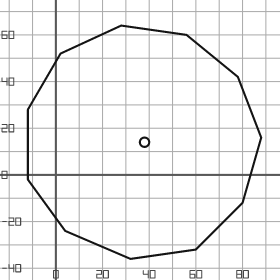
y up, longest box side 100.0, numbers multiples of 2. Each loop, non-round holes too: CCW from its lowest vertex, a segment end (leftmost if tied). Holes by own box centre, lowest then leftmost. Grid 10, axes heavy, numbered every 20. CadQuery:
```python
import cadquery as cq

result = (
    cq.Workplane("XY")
    .moveTo(32.0, -36.0)
    .lineTo(60.0, -32.0)
    .lineTo(80.0, -12.0)
    .lineTo(88.0, 16.0)
    .lineTo(78.0, 42.0)
    .lineTo(56.0, 60.0)
    .lineTo(28.0, 64.0)
    .lineTo(2.0, 52.0)
    .lineTo(-12.0, 28.0)
    .lineTo(-12.0, -2.0)
    .lineTo(4.0, -24.0)
    .close()
    .moveTo(38.0, 14.0)
    .circle(2.0)
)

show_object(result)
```